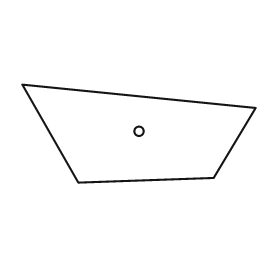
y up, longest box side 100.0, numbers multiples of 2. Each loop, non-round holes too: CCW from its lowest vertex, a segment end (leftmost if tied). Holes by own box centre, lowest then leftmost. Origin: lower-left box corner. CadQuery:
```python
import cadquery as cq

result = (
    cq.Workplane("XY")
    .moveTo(24.0, 0.0)
    .lineTo(82.0, 2.0)
    .lineTo(100.0, 32.0)
    .lineTo(0.0, 42.0)
    .close()
    .moveTo(50.0, 22.0)
    .circle(2.0)
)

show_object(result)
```